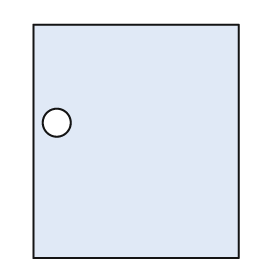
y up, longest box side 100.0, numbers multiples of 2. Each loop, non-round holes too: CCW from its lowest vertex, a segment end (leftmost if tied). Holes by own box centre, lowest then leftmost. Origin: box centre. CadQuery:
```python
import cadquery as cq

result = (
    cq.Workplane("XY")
    .moveTo(-44.0, -50.0)
    .lineTo(44.0, -50.0)
    .lineTo(44.0, 50.0)
    .lineTo(-44.0, 50.0)
    .close()
    .moveTo(-34.0, 8.0)
    .circle(6.0)
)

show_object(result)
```